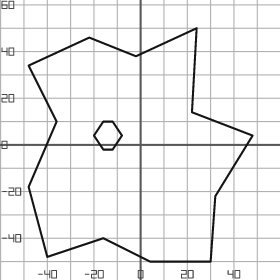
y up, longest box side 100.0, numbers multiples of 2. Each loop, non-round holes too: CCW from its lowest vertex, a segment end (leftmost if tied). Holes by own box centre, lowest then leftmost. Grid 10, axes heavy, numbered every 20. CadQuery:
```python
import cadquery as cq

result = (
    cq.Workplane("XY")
    .moveTo(4.0, -50.0)
    .lineTo(30.0, -50.0)
    .lineTo(32.0, -22.0)
    .lineTo(48.0, 4.0)
    .lineTo(22.0, 14.0)
    .lineTo(24.0, 50.0)
    .lineTo(-2.0, 38.0)
    .lineTo(-22.0, 46.0)
    .lineTo(-48.0, 34.0)
    .lineTo(-36.0, 10.0)
    .lineTo(-48.0, -18.0)
    .lineTo(-40.0, -48.0)
    .lineTo(-16.0, -40.0)
    .close()
    .moveTo(-16.0, -2.0)
    .lineTo(-12.0, -2.0)
    .lineTo(-8.0, 4.0)
    .lineTo(-12.0, 10.0)
    .lineTo(-16.0, 10.0)
    .lineTo(-20.0, 4.0)
    .close()
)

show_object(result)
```